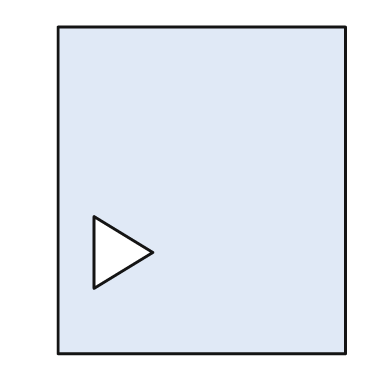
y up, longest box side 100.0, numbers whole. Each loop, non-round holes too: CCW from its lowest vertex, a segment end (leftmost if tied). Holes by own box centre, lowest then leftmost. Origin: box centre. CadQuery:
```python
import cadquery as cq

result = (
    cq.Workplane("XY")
    .moveTo(-44.0, -50.0)
    .lineTo(44.0, -50.0)
    .lineTo(44.0, 50.0)
    .lineTo(-44.0, 50.0)
    .close()
    .moveTo(-33.0, -30.0)
    .lineTo(-15.0, -19.0)
    .lineTo(-33.0, -8.0)
    .close()
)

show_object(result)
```